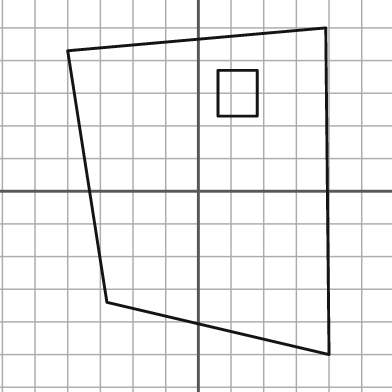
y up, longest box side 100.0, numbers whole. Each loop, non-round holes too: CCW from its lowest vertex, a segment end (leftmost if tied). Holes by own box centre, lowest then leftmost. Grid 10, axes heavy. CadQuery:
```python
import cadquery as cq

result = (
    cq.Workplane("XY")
    .moveTo(40.0, -50.0)
    .lineTo(39.0, 50.0)
    .lineTo(-40.0, 43.0)
    .lineTo(-28.0, -34.0)
    .close()
    .moveTo(6.0, 23.0)
    .lineTo(18.0, 23.0)
    .lineTo(18.0, 37.0)
    .lineTo(6.0, 37.0)
    .close()
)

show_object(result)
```